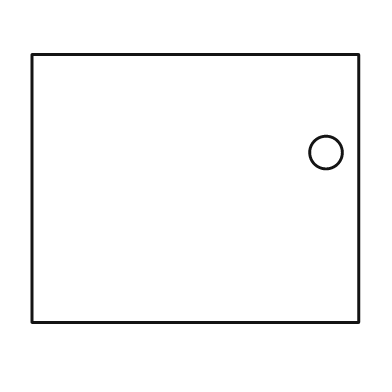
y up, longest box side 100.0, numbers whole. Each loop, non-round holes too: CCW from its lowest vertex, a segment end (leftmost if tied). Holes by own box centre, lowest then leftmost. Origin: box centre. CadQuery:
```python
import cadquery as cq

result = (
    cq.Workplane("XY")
    .moveTo(-50.0, -41.0)
    .lineTo(50.0, -41.0)
    .lineTo(50.0, 41.0)
    .lineTo(-50.0, 41.0)
    .close()
    .moveTo(40.0, 11.0)
    .circle(5.0)
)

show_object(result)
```